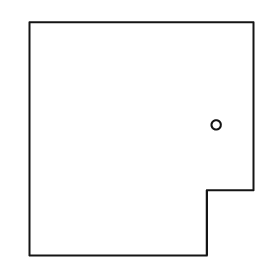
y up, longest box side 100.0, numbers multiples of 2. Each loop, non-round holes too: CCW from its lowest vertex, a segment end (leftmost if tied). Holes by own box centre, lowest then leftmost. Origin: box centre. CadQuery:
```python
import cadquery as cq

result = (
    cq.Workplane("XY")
    .moveTo(-48.0, -50.0)
    .lineTo(28.0, -50.0)
    .lineTo(28.0, -22.0)
    .lineTo(48.0, -22.0)
    .lineTo(48.0, 50.0)
    .lineTo(-48.0, 50.0)
    .close()
    .moveTo(32.0, 6.0)
    .circle(2.0)
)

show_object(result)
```